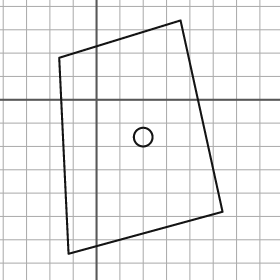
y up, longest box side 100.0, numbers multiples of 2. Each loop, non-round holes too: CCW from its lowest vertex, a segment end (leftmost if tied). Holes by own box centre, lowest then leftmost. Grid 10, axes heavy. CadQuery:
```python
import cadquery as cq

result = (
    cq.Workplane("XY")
    .moveTo(-12.0, -66.0)
    .lineTo(54.0, -48.0)
    .lineTo(36.0, 34.0)
    .lineTo(-16.0, 18.0)
    .close()
    .moveTo(20.0, -16.0)
    .circle(4.0)
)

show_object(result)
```